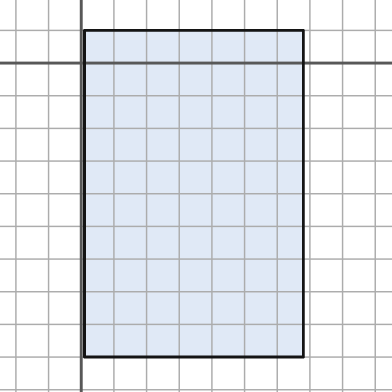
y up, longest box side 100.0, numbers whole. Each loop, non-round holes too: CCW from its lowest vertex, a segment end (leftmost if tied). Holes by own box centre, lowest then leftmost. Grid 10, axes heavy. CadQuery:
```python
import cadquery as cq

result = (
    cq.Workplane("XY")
    .moveTo(1.0, -90.0)
    .lineTo(68.0, -90.0)
    .lineTo(68.0, 10.0)
    .lineTo(1.0, 10.0)
    .close()
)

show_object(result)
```